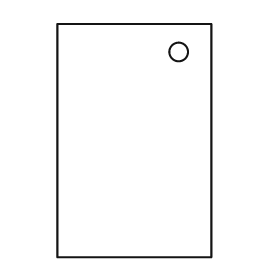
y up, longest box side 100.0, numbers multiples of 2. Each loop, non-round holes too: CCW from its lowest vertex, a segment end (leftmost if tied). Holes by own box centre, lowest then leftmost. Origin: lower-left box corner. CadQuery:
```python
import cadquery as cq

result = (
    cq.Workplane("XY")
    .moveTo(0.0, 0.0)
    .lineTo(66.0, 0.0)
    .lineTo(66.0, 100.0)
    .lineTo(0.0, 100.0)
    .close()
    .moveTo(52.0, 88.0)
    .circle(4.0)
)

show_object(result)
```